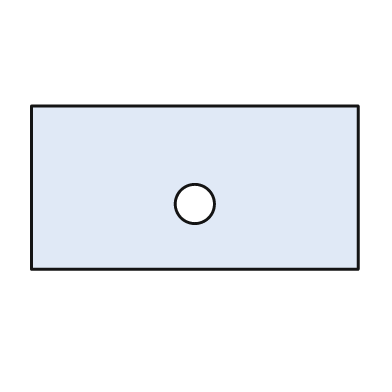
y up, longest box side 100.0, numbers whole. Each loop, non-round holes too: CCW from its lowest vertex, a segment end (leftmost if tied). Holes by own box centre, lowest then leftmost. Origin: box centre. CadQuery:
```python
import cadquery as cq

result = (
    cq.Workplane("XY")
    .moveTo(-50.0, -25.0)
    .lineTo(50.0, -25.0)
    .lineTo(50.0, 25.0)
    .lineTo(-50.0, 25.0)
    .close()
    .moveTo(0.0, -5.0)
    .circle(6.0)
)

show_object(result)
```